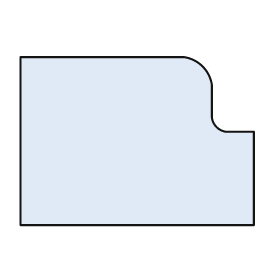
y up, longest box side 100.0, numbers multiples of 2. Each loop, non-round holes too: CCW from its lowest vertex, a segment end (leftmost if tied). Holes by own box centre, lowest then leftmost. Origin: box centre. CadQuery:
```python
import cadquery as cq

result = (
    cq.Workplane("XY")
    .moveTo(-50.0, -36.0)
    .lineTo(50.0, -36.0)
    .lineTo(50.0, 4.0)
    .lineTo(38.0, 4.0)
    .threePointArc((34.0, 6.0), (32.0, 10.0))
    .lineTo(32.0, 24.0)
    .threePointArc((28.0, 32.0), (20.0, 36.0))
    .lineTo(-50.0, 36.0)
    .close()
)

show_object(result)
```